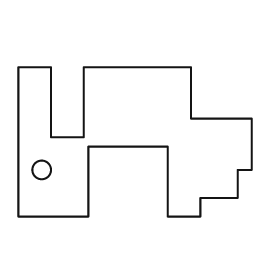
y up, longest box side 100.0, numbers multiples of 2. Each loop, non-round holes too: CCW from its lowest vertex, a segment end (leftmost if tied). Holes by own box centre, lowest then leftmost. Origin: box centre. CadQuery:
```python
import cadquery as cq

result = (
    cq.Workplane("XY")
    .moveTo(-50.0, -32.0)
    .lineTo(-20.0, -32.0)
    .lineTo(-20.0, -2.0)
    .lineTo(14.0, -2.0)
    .lineTo(14.0, -32.0)
    .lineTo(28.0, -32.0)
    .lineTo(28.0, -24.0)
    .lineTo(44.0, -24.0)
    .lineTo(44.0, -12.0)
    .lineTo(50.0, -12.0)
    .lineTo(50.0, 10.0)
    .lineTo(24.0, 10.0)
    .lineTo(24.0, 32.0)
    .lineTo(-22.0, 32.0)
    .lineTo(-22.0, 2.0)
    .lineTo(-36.0, 2.0)
    .lineTo(-36.0, 32.0)
    .lineTo(-50.0, 32.0)
    .close()
    .moveTo(-40.0, -12.0)
    .circle(4.0)
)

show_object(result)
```